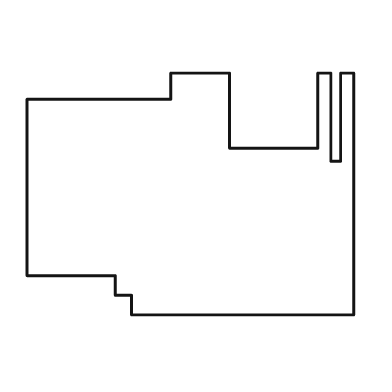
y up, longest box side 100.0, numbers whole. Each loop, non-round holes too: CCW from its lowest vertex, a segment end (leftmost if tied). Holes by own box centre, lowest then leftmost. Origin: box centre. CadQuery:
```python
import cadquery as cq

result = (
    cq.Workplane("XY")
    .moveTo(-18.0, -37.0)
    .lineTo(50.0, -37.0)
    .lineTo(50.0, 37.0)
    .lineTo(46.0, 37.0)
    .lineTo(46.0, 10.0)
    .lineTo(43.0, 10.0)
    .lineTo(43.0, 37.0)
    .lineTo(39.0, 37.0)
    .lineTo(39.0, 14.0)
    .lineTo(12.0, 14.0)
    .lineTo(12.0, 37.0)
    .lineTo(-6.0, 37.0)
    .lineTo(-6.0, 29.0)
    .lineTo(-50.0, 29.0)
    .lineTo(-50.0, -25.0)
    .lineTo(-23.0, -25.0)
    .lineTo(-23.0, -31.0)
    .lineTo(-18.0, -31.0)
    .close()
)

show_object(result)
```